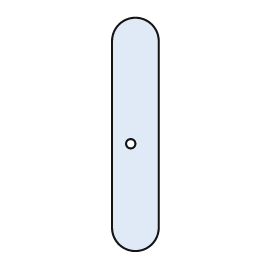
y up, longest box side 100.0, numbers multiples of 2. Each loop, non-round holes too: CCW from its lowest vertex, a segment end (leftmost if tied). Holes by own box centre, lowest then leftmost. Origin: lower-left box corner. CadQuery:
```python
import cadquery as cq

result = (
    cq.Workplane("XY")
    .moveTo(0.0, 10.0)
    .threePointArc((10.0, 0.0), (20.0, 10.0))
    .lineTo(20.0, 90.0)
    .threePointArc((10.0, 100.0), (0.0, 90.0))
    .close()
    .moveTo(8.0, 46.0)
    .circle(2.0)
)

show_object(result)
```